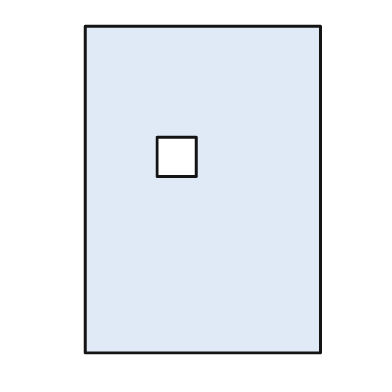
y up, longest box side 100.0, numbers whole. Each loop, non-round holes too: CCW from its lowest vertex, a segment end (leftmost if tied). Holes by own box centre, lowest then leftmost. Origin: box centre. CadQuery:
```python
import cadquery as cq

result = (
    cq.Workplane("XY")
    .moveTo(-36.0, -50.0)
    .lineTo(36.0, -50.0)
    .lineTo(36.0, 50.0)
    .lineTo(-36.0, 50.0)
    .close()
    .moveTo(-14.0, 4.0)
    .lineTo(-2.0, 4.0)
    .lineTo(-2.0, 16.0)
    .lineTo(-14.0, 16.0)
    .close()
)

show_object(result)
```